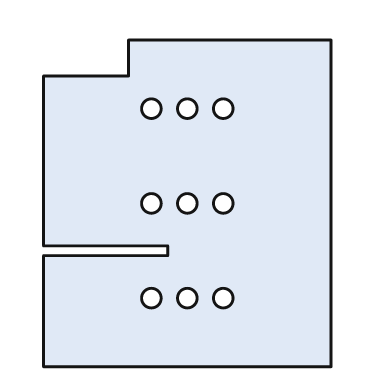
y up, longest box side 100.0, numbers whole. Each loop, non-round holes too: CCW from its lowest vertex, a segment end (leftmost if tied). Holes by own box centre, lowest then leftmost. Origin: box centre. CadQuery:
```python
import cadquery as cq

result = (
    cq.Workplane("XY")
    .moveTo(-44.0, -50.0)
    .lineTo(44.0, -50.0)
    .lineTo(44.0, 50.0)
    .lineTo(-18.0, 50.0)
    .lineTo(-18.0, 39.0)
    .lineTo(-44.0, 39.0)
    .lineTo(-44.0, -13.0)
    .lineTo(-6.0, -13.0)
    .lineTo(-6.0, -16.0)
    .lineTo(-44.0, -16.0)
    .close()
    .moveTo(-11.0, -29.0)
    .circle(3.0)
    .moveTo(0.0, -29.0)
    .circle(3.0)
    .moveTo(11.0, -29.0)
    .circle(3.0)
    .moveTo(-11.0, 0.0)
    .circle(3.0)
    .moveTo(0.0, 0.0)
    .circle(3.0)
    .moveTo(11.0, 0.0)
    .circle(3.0)
    .moveTo(-11.0, 29.0)
    .circle(3.0)
    .moveTo(0.0, 29.0)
    .circle(3.0)
    .moveTo(11.0, 29.0)
    .circle(3.0)
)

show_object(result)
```